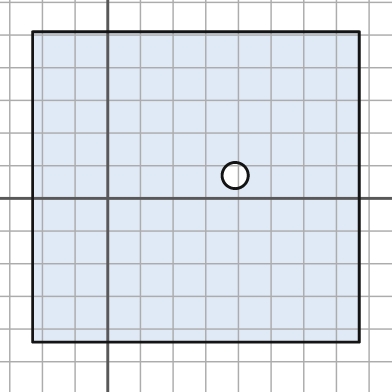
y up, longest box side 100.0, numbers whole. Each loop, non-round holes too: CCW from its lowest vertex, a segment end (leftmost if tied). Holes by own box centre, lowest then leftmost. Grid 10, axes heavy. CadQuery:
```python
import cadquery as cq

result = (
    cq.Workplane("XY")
    .moveTo(-23.0, -44.0)
    .lineTo(77.0, -44.0)
    .lineTo(77.0, 51.0)
    .lineTo(-23.0, 51.0)
    .close()
    .moveTo(39.0, 7.0)
    .circle(4.0)
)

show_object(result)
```